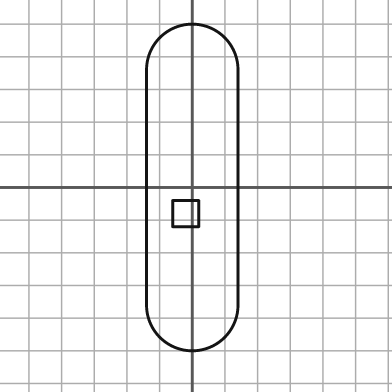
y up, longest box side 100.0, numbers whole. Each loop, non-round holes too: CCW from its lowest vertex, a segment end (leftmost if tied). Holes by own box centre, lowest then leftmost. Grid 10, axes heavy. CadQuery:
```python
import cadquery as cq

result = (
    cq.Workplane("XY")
    .moveTo(-14.0, -36.0)
    .threePointArc((0.0, -50.0), (14.0, -36.0))
    .lineTo(14.0, 36.0)
    .threePointArc((0.0, 50.0), (-14.0, 36.0))
    .close()
    .moveTo(-6.0, -12.0)
    .lineTo(2.0, -12.0)
    .lineTo(2.0, -4.0)
    .lineTo(-6.0, -4.0)
    .close()
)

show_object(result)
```